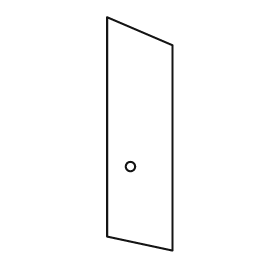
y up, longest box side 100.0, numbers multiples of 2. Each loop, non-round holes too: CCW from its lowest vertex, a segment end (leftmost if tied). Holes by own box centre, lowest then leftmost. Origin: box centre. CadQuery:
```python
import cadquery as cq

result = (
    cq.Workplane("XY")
    .moveTo(14.0, -50.0)
    .lineTo(14.0, 38.0)
    .lineTo(-14.0, 50.0)
    .lineTo(-14.0, -44.0)
    .close()
    .moveTo(-4.0, -14.0)
    .circle(2.0)
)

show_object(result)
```